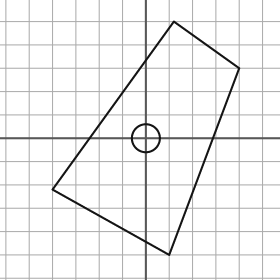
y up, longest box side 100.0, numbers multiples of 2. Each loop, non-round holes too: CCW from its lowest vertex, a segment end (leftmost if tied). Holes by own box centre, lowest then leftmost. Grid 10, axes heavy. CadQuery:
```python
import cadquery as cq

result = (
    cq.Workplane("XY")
    .moveTo(10.0, -50.0)
    .lineTo(40.0, 30.0)
    .lineTo(12.0, 50.0)
    .lineTo(-40.0, -22.0)
    .close()
    .moveTo(0.0, 0.0)
    .circle(6.0)
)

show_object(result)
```